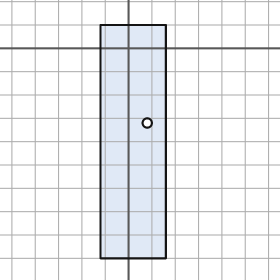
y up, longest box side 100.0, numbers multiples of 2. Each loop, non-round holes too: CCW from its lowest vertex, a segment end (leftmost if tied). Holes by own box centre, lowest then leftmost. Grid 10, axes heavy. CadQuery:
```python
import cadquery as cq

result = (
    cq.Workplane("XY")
    .moveTo(-12.0, -90.0)
    .lineTo(16.0, -90.0)
    .lineTo(16.0, 10.0)
    .lineTo(-12.0, 10.0)
    .close()
    .moveTo(8.0, -32.0)
    .circle(2.0)
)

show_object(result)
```